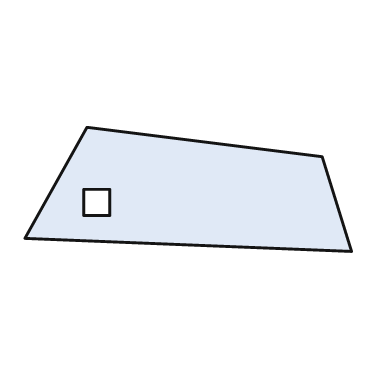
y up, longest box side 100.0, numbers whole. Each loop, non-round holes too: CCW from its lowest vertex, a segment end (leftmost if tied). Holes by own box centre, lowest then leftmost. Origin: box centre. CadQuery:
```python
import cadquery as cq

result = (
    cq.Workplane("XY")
    .moveTo(50.0, -19.0)
    .lineTo(41.0, 10.0)
    .lineTo(-31.0, 19.0)
    .lineTo(-50.0, -15.0)
    .close()
    .moveTo(-32.0, -8.0)
    .lineTo(-24.0, -8.0)
    .lineTo(-24.0, 0.0)
    .lineTo(-32.0, 0.0)
    .close()
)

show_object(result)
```